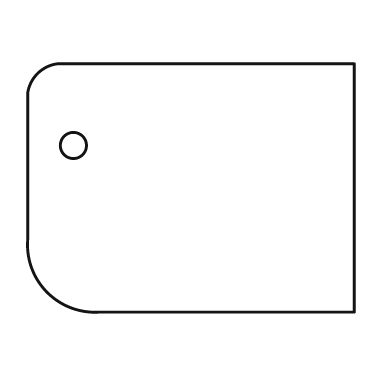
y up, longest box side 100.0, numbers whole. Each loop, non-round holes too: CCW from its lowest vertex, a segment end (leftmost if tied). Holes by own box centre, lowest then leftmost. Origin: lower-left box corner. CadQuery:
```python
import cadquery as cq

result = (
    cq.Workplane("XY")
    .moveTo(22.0, 0.0)
    .lineTo(100.0, 0.0)
    .lineTo(100.0, 76.0)
    .lineTo(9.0, 76.0)
    .threePointArc((3.0, 73.0), (0.0, 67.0))
    .lineTo(0.0, 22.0)
    .threePointArc((6.0, 6.0), (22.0, 0.0))
    .close()
    .moveTo(14.0, 51.0)
    .circle(4.0)
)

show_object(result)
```